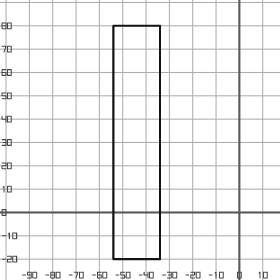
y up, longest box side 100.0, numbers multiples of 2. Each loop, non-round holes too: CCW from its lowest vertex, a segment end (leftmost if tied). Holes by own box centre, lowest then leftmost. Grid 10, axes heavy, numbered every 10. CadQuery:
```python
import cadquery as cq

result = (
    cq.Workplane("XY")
    .moveTo(-54.0, -20.0)
    .lineTo(-34.0, -20.0)
    .lineTo(-34.0, 80.0)
    .lineTo(-54.0, 80.0)
    .close()
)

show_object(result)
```